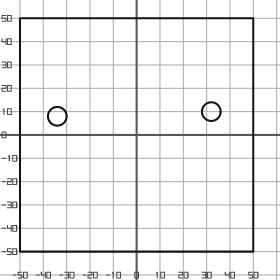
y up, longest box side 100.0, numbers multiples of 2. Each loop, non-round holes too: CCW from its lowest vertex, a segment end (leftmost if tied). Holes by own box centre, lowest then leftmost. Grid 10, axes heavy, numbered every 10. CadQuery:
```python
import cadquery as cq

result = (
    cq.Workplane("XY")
    .moveTo(-50.0, -50.0)
    .lineTo(50.0, -50.0)
    .lineTo(50.0, 50.0)
    .lineTo(-50.0, 50.0)
    .close()
    .moveTo(-34.0, 8.0)
    .circle(4.0)
    .moveTo(32.0, 10.0)
    .circle(4.0)
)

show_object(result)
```